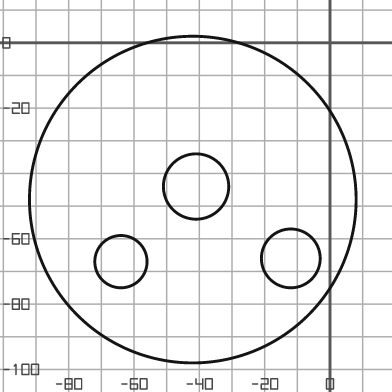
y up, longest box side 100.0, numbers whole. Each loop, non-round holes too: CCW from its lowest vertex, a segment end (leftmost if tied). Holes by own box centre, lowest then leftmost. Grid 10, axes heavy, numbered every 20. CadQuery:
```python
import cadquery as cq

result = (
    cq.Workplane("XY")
    .moveTo(-42.0, -48.0)
    .circle(50.0)
    .moveTo(-64.0, -67.0)
    .circle(8.0)
    .moveTo(-12.0, -66.0)
    .circle(9.0)
    .moveTo(-41.0, -44.0)
    .circle(10.0)
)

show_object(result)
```